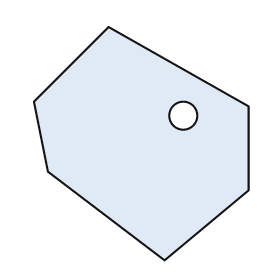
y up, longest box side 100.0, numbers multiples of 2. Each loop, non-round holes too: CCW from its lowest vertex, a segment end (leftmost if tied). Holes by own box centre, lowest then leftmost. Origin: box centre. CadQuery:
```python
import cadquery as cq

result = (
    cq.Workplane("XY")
    .moveTo(10.0, -50.0)
    .lineTo(46.0, -20.0)
    .lineTo(46.0, 16.0)
    .lineTo(-14.0, 50.0)
    .lineTo(-46.0, 18.0)
    .lineTo(-40.0, -12.0)
    .close()
    .moveTo(18.0, 12.0)
    .circle(6.0)
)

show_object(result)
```